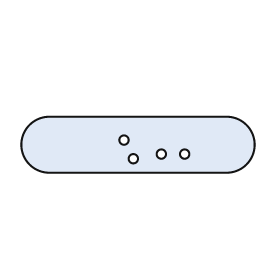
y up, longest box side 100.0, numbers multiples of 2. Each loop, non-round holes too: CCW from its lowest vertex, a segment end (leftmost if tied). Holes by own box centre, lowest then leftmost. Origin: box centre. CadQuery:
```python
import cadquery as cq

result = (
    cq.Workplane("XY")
    .moveTo(-38.0, -12.0)
    .lineTo(38.0, -12.0)
    .threePointArc((50.0, 0.0), (38.0, 12.0))
    .lineTo(-38.0, 12.0)
    .threePointArc((-50.0, 0.0), (-38.0, -12.0))
    .close()
    .moveTo(-2.0, -6.0)
    .circle(2.0)
    .moveTo(10.0, -4.0)
    .circle(2.0)
    .moveTo(20.0, -4.0)
    .circle(2.0)
    .moveTo(-6.0, 2.0)
    .circle(2.0)
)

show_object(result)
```